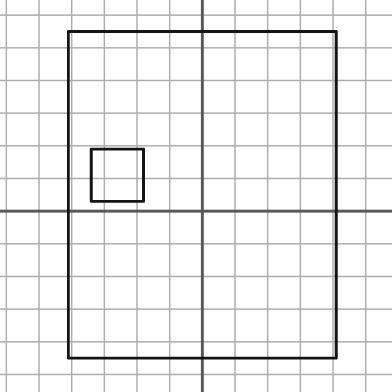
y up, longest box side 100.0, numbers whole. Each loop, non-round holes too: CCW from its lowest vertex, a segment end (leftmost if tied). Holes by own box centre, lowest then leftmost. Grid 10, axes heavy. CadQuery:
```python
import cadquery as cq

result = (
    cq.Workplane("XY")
    .moveTo(-41.0, -45.0)
    .lineTo(41.0, -45.0)
    .lineTo(41.0, 55.0)
    .lineTo(-41.0, 55.0)
    .close()
    .moveTo(-34.0, 3.0)
    .lineTo(-18.0, 3.0)
    .lineTo(-18.0, 19.0)
    .lineTo(-34.0, 19.0)
    .close()
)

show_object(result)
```